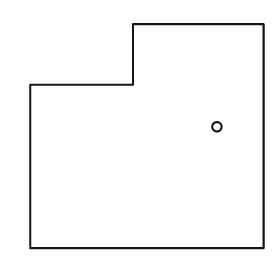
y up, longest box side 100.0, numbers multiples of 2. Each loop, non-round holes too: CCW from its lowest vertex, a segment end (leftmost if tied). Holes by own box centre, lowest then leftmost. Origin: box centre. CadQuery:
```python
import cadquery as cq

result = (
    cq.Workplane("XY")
    .moveTo(-50.0, -48.0)
    .lineTo(50.0, -48.0)
    .lineTo(50.0, 48.0)
    .lineTo(-6.0, 48.0)
    .lineTo(-6.0, 22.0)
    .lineTo(-50.0, 22.0)
    .close()
    .moveTo(30.0, 4.0)
    .circle(2.0)
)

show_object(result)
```